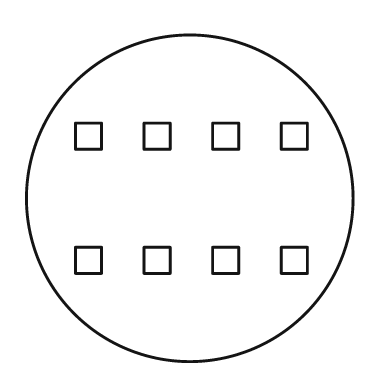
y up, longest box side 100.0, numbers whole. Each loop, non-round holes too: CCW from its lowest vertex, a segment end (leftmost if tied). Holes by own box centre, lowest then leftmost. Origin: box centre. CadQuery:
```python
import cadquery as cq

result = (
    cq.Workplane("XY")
    .moveTo(0.0, 0.0)
    .circle(50.0)
    .moveTo(-35.0, -23.0)
    .lineTo(-27.0, -23.0)
    .lineTo(-27.0, -15.0)
    .lineTo(-35.0, -15.0)
    .close()
    .moveTo(-14.0, -23.0)
    .lineTo(-6.0, -23.0)
    .lineTo(-6.0, -15.0)
    .lineTo(-14.0, -15.0)
    .close()
    .moveTo(7.0, -23.0)
    .lineTo(15.0, -23.0)
    .lineTo(15.0, -15.0)
    .lineTo(7.0, -15.0)
    .close()
    .moveTo(28.0, -23.0)
    .lineTo(36.0, -23.0)
    .lineTo(36.0, -15.0)
    .lineTo(28.0, -15.0)
    .close()
    .moveTo(-35.0, 15.0)
    .lineTo(-27.0, 15.0)
    .lineTo(-27.0, 23.0)
    .lineTo(-35.0, 23.0)
    .close()
    .moveTo(-14.0, 15.0)
    .lineTo(-6.0, 15.0)
    .lineTo(-6.0, 23.0)
    .lineTo(-14.0, 23.0)
    .close()
    .moveTo(7.0, 15.0)
    .lineTo(15.0, 15.0)
    .lineTo(15.0, 23.0)
    .lineTo(7.0, 23.0)
    .close()
    .moveTo(28.0, 15.0)
    .lineTo(36.0, 15.0)
    .lineTo(36.0, 23.0)
    .lineTo(28.0, 23.0)
    .close()
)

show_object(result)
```